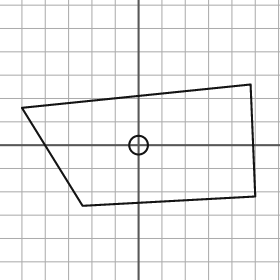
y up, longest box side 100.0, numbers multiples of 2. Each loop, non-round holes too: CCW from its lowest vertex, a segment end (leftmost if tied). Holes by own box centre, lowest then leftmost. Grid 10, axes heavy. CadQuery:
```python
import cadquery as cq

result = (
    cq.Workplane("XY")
    .moveTo(-24.0, -26.0)
    .lineTo(50.0, -22.0)
    .lineTo(48.0, 26.0)
    .lineTo(-50.0, 16.0)
    .close()
    .moveTo(0.0, 0.0)
    .circle(4.0)
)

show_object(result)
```